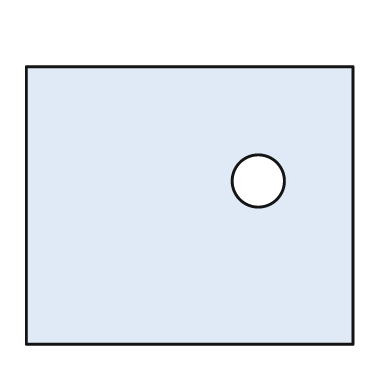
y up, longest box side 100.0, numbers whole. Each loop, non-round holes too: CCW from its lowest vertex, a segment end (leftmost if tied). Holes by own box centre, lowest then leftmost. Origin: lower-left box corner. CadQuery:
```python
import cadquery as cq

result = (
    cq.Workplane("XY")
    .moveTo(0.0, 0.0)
    .lineTo(100.0, 0.0)
    .lineTo(100.0, 85.0)
    .lineTo(0.0, 85.0)
    .close()
    .moveTo(71.0, 50.0)
    .circle(8.0)
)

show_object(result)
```